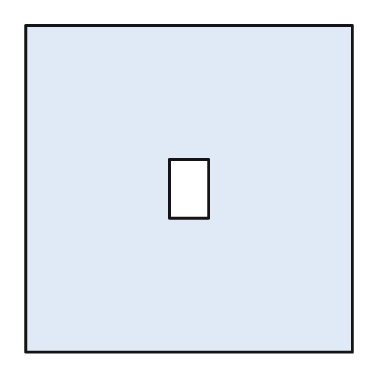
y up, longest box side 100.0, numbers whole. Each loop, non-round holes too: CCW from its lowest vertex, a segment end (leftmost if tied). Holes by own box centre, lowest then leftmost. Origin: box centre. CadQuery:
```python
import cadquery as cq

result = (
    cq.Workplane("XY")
    .moveTo(-50.0, -50.0)
    .lineTo(50.0, -50.0)
    .lineTo(50.0, 50.0)
    .lineTo(-50.0, 50.0)
    .close()
    .moveTo(-6.0, -9.0)
    .lineTo(6.0, -9.0)
    .lineTo(6.0, 9.0)
    .lineTo(-6.0, 9.0)
    .close()
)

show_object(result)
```